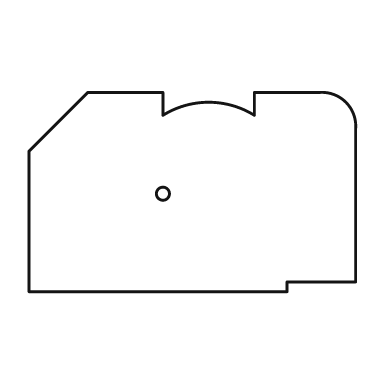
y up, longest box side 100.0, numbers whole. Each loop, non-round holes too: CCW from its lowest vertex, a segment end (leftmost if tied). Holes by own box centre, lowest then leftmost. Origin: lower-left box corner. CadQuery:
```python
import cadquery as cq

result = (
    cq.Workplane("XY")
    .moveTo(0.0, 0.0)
    .lineTo(79.0, 0.0)
    .lineTo(79.0, 3.0)
    .lineTo(100.0, 3.0)
    .lineTo(100.0, 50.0)
    .threePointArc((97.0, 58.0), (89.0, 61.0))
    .lineTo(69.0, 61.0)
    .lineTo(69.0, 54.0)
    .threePointArc((55.0, 58.0), (41.0, 54.0))
    .lineTo(41.0, 61.0)
    .lineTo(18.0, 61.0)
    .lineTo(0.0, 43.0)
    .close()
    .moveTo(41.0, 30.0)
    .circle(2.0)
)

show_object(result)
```